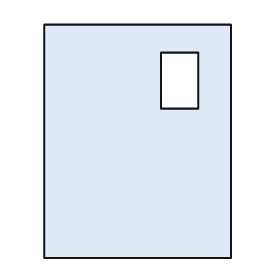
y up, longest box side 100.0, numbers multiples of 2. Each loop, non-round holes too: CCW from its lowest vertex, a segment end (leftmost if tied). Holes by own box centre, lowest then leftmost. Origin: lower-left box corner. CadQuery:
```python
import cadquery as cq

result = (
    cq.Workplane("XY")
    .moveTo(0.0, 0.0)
    .lineTo(80.0, 0.0)
    .lineTo(80.0, 100.0)
    .lineTo(0.0, 100.0)
    .close()
    .moveTo(50.0, 64.0)
    .lineTo(66.0, 64.0)
    .lineTo(66.0, 88.0)
    .lineTo(50.0, 88.0)
    .close()
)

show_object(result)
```